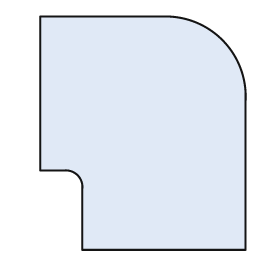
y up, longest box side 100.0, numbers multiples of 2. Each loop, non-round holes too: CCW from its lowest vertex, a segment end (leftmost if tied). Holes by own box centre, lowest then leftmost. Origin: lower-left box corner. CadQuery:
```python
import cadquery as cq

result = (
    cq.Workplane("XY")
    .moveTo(18.0, 0.0)
    .lineTo(88.0, 0.0)
    .lineTo(88.0, 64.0)
    .threePointArc((78.0, 90.0), (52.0, 100.0))
    .lineTo(0.0, 100.0)
    .lineTo(0.0, 34.0)
    .lineTo(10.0, 34.0)
    .threePointArc((16.0, 32.0), (18.0, 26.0))
    .close()
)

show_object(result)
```